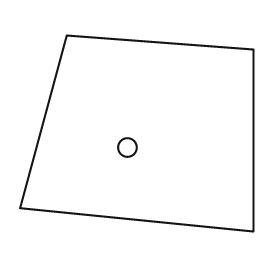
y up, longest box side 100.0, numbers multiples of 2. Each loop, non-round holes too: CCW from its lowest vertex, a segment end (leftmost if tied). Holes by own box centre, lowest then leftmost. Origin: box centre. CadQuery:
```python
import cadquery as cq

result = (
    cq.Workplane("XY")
    .moveTo(50.0, -42.0)
    .lineTo(50.0, 36.0)
    .lineTo(-30.0, 42.0)
    .lineTo(-50.0, -32.0)
    .close()
    .moveTo(-4.0, -6.0)
    .circle(4.0)
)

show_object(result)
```